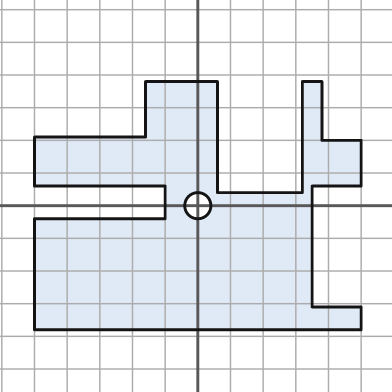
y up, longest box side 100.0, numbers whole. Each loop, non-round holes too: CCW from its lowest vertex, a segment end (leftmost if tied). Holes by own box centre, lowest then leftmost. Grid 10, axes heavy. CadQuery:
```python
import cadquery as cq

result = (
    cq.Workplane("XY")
    .moveTo(-50.0, -38.0)
    .lineTo(50.0, -38.0)
    .lineTo(50.0, -31.0)
    .lineTo(35.0, -31.0)
    .lineTo(35.0, 6.0)
    .lineTo(50.0, 6.0)
    .lineTo(50.0, 20.0)
    .lineTo(38.0, 20.0)
    .lineTo(38.0, 38.0)
    .lineTo(32.0, 38.0)
    .lineTo(32.0, 4.0)
    .lineTo(6.0, 4.0)
    .lineTo(6.0, 38.0)
    .lineTo(-16.0, 38.0)
    .lineTo(-16.0, 21.0)
    .lineTo(-50.0, 21.0)
    .lineTo(-50.0, 6.0)
    .lineTo(-10.0, 6.0)
    .lineTo(-10.0, -4.0)
    .lineTo(-50.0, -4.0)
    .close()
    .moveTo(0.0, 0.0)
    .circle(4.0)
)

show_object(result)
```